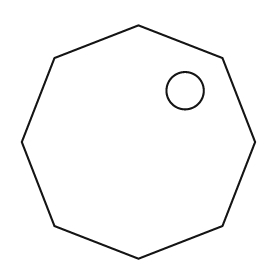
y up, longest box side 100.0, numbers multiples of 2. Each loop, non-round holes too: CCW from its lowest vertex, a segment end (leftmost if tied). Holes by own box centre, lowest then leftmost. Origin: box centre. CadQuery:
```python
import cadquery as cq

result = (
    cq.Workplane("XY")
    .moveTo(0.0, -50.0)
    .lineTo(36.0, -36.0)
    .lineTo(50.0, 0.0)
    .lineTo(36.0, 36.0)
    .lineTo(0.0, 50.0)
    .lineTo(-36.0, 36.0)
    .lineTo(-50.0, 0.0)
    .lineTo(-36.0, -36.0)
    .close()
    .moveTo(20.0, 22.0)
    .circle(8.0)
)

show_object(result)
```